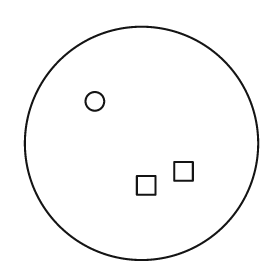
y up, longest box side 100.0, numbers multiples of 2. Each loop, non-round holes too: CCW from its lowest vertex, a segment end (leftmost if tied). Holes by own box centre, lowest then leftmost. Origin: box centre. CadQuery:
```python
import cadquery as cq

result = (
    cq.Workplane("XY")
    .moveTo(0.0, 0.0)
    .circle(50.0)
    .moveTo(-2.0, -22.0)
    .lineTo(6.0, -22.0)
    .lineTo(6.0, -14.0)
    .lineTo(-2.0, -14.0)
    .close()
    .moveTo(14.0, -16.0)
    .lineTo(22.0, -16.0)
    .lineTo(22.0, -8.0)
    .lineTo(14.0, -8.0)
    .close()
    .moveTo(-20.0, 18.0)
    .circle(4.0)
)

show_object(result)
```